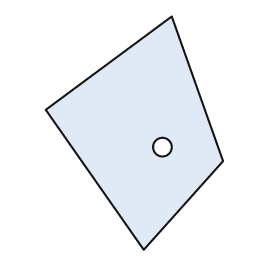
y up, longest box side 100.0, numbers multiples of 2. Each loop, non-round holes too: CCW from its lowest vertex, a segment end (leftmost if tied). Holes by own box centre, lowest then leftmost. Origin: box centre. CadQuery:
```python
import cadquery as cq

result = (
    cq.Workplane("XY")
    .moveTo(4.0, -50.0)
    .lineTo(38.0, -12.0)
    .lineTo(16.0, 50.0)
    .lineTo(-38.0, 10.0)
    .close()
    .moveTo(12.0, -6.0)
    .circle(4.0)
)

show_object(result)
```